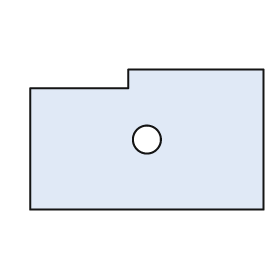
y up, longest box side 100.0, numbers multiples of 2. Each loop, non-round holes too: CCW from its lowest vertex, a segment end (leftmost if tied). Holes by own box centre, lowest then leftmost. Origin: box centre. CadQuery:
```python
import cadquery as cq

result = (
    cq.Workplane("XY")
    .moveTo(-50.0, -30.0)
    .lineTo(50.0, -30.0)
    .lineTo(50.0, 30.0)
    .lineTo(-8.0, 30.0)
    .lineTo(-8.0, 22.0)
    .lineTo(-50.0, 22.0)
    .close()
    .moveTo(0.0, 0.0)
    .circle(6.0)
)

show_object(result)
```